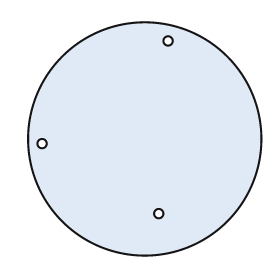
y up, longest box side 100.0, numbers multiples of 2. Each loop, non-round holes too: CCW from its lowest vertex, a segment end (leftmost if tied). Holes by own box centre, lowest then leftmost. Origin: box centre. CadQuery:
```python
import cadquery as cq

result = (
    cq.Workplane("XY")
    .moveTo(0.0, 0.0)
    .circle(50.0)
    .moveTo(6.0, -32.0)
    .circle(2.0)
    .moveTo(-44.0, -2.0)
    .circle(2.0)
    .moveTo(10.0, 42.0)
    .circle(2.0)
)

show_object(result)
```